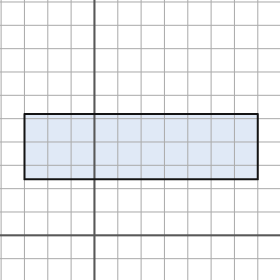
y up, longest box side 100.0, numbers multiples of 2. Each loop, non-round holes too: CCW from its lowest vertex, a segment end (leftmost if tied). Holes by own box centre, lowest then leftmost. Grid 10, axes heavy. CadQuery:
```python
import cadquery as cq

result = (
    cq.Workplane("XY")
    .moveTo(-30.0, 24.0)
    .lineTo(70.0, 24.0)
    .lineTo(70.0, 52.0)
    .lineTo(-30.0, 52.0)
    .close()
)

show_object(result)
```